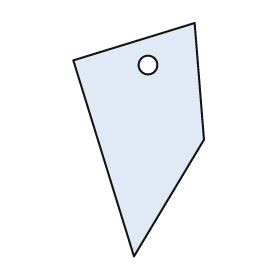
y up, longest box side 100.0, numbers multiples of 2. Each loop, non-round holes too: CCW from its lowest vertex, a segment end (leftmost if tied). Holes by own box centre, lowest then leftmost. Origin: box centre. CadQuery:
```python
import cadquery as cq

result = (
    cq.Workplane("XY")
    .moveTo(-2.0, -50.0)
    .lineTo(28.0, 0.0)
    .lineTo(24.0, 50.0)
    .lineTo(-28.0, 34.0)
    .close()
    .moveTo(4.0, 32.0)
    .circle(4.0)
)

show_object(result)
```